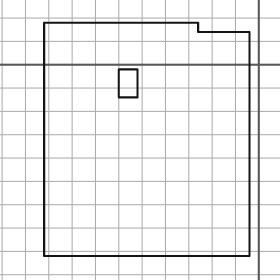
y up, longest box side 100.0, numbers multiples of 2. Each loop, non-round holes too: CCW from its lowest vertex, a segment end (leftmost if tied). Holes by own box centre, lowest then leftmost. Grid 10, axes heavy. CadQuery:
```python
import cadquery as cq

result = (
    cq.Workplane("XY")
    .moveTo(-92.0, -82.0)
    .lineTo(-4.0, -82.0)
    .lineTo(-4.0, 14.0)
    .lineTo(-26.0, 14.0)
    .lineTo(-26.0, 18.0)
    .lineTo(-92.0, 18.0)
    .close()
    .moveTo(-60.0, -14.0)
    .lineTo(-52.0, -14.0)
    .lineTo(-52.0, -2.0)
    .lineTo(-60.0, -2.0)
    .close()
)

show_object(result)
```